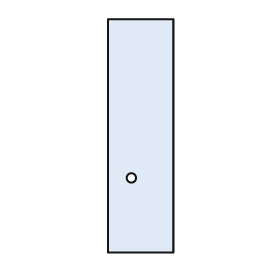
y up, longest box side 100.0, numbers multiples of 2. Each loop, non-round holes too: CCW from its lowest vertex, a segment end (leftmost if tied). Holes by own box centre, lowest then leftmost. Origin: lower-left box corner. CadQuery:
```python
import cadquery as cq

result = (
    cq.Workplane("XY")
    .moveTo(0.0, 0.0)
    .lineTo(28.0, 0.0)
    .lineTo(28.0, 100.0)
    .lineTo(0.0, 100.0)
    .close()
    .moveTo(10.0, 32.0)
    .circle(2.0)
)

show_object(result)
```